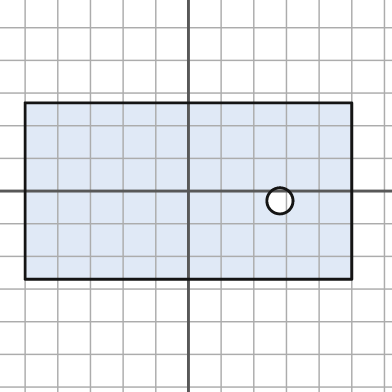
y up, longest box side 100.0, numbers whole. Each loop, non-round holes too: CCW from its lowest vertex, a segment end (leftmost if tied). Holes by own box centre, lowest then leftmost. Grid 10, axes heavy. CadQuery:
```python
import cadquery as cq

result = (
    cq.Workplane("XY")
    .moveTo(-50.0, -27.0)
    .lineTo(50.0, -27.0)
    .lineTo(50.0, 27.0)
    .lineTo(-50.0, 27.0)
    .close()
    .moveTo(28.0, -3.0)
    .circle(4.0)
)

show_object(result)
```